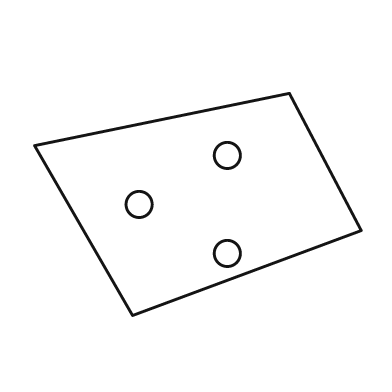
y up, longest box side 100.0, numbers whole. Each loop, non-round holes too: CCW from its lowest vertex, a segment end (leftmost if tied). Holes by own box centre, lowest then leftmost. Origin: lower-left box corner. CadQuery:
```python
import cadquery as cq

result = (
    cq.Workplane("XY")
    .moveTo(30.0, 0.0)
    .lineTo(100.0, 26.0)
    .lineTo(78.0, 68.0)
    .lineTo(0.0, 52.0)
    .close()
    .moveTo(59.0, 19.0)
    .circle(4.0)
    .moveTo(32.0, 34.0)
    .circle(4.0)
    .moveTo(59.0, 49.0)
    .circle(4.0)
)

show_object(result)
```